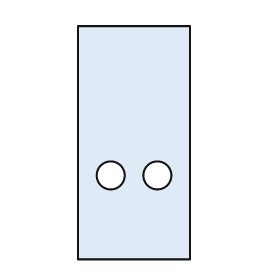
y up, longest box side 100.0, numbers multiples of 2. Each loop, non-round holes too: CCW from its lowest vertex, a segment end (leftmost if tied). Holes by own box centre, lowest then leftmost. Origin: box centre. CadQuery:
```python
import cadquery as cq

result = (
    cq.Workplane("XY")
    .moveTo(-24.0, -50.0)
    .lineTo(24.0, -50.0)
    .lineTo(24.0, 50.0)
    .lineTo(-24.0, 50.0)
    .close()
    .moveTo(-10.0, -14.0)
    .circle(6.0)
    .moveTo(10.0, -14.0)
    .circle(6.0)
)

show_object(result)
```